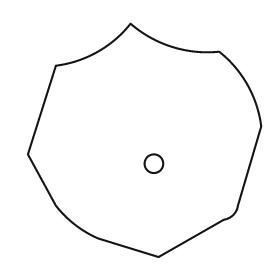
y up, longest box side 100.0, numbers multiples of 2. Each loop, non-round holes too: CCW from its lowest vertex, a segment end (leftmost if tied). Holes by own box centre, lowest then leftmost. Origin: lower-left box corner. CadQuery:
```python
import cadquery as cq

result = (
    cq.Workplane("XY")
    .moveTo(56.0, 0.0)
    .lineTo(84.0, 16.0)
    .threePointArc((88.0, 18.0), (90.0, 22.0))
    .lineTo(100.0, 56.0)
    .threePointArc((94.0, 74.0), (82.0, 88.0))
    .threePointArc((62.0, 90.0), (44.0, 100.0))
    .threePointArc((30.0, 88.0), (12.0, 82.0))
    .lineTo(0.0, 44.0)
    .lineTo(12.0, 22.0)
    .threePointArc((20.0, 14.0), (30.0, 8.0))
    .close()
    .moveTo(54.0, 40.0)
    .circle(4.0)
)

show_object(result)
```